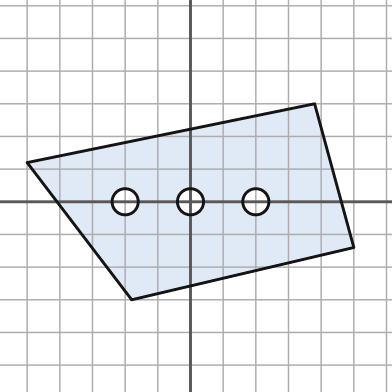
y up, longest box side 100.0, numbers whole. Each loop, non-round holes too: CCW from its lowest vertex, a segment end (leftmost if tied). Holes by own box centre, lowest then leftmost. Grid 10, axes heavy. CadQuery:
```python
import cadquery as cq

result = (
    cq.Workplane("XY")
    .moveTo(-18.0, -30.0)
    .lineTo(50.0, -14.0)
    .lineTo(38.0, 30.0)
    .lineTo(-50.0, 12.0)
    .close()
    .moveTo(-20.0, 0.0)
    .circle(4.0)
    .moveTo(0.0, 0.0)
    .circle(4.0)
    .moveTo(20.0, 0.0)
    .circle(4.0)
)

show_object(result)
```